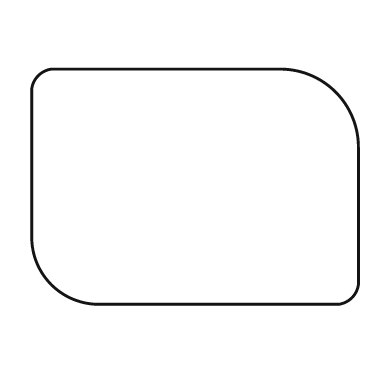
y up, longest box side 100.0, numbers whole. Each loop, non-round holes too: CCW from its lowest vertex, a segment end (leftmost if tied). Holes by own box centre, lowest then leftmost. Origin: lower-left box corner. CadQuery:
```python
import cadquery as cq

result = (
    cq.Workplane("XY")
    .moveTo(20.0, 0.0)
    .lineTo(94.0, 0.0)
    .threePointArc((98.0, 2.0), (100.0, 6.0))
    .lineTo(100.0, 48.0)
    .threePointArc((93.0, 65.0), (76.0, 72.0))
    .lineTo(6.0, 72.0)
    .threePointArc((2.0, 70.0), (0.0, 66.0))
    .lineTo(0.0, 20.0)
    .threePointArc((6.0, 6.0), (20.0, 0.0))
    .close()
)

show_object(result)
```